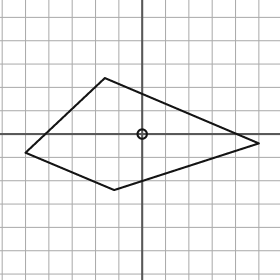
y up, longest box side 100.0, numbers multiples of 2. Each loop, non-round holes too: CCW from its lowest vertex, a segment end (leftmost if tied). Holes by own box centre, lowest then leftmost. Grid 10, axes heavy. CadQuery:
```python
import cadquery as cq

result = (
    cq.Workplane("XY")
    .moveTo(-12.0, -24.0)
    .lineTo(50.0, -4.0)
    .lineTo(-16.0, 24.0)
    .lineTo(-50.0, -8.0)
    .close()
    .moveTo(0.0, 0.0)
    .circle(2.0)
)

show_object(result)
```